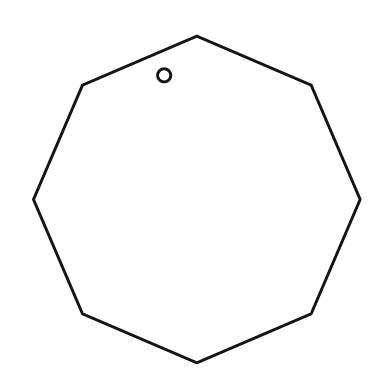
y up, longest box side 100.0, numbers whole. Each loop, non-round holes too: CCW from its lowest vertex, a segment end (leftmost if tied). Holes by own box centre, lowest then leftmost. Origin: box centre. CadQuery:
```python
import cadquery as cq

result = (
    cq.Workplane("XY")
    .moveTo(0.0, -50.0)
    .lineTo(35.0, -35.0)
    .lineTo(50.0, 0.0)
    .lineTo(35.0, 35.0)
    .lineTo(0.0, 50.0)
    .lineTo(-35.0, 35.0)
    .lineTo(-50.0, 0.0)
    .lineTo(-35.0, -35.0)
    .close()
    .moveTo(-10.0, 38.0)
    .circle(2.0)
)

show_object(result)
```